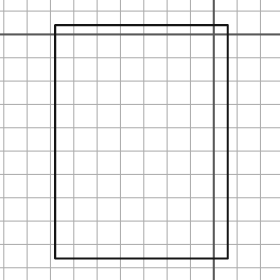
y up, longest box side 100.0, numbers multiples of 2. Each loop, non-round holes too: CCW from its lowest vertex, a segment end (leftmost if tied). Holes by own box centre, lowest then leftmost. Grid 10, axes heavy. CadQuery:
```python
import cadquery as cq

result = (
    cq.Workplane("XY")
    .moveTo(-68.0, -96.0)
    .lineTo(6.0, -96.0)
    .lineTo(6.0, 4.0)
    .lineTo(-68.0, 4.0)
    .close()
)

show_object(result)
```